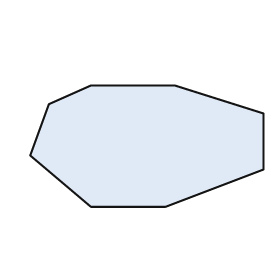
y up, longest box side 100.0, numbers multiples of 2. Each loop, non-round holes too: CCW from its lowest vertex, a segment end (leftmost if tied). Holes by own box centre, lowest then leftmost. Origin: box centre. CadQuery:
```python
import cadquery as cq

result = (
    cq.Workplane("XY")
    .moveTo(-24.0, -26.0)
    .lineTo(8.0, -26.0)
    .lineTo(50.0, -10.0)
    .lineTo(50.0, 14.0)
    .lineTo(12.0, 26.0)
    .lineTo(-24.0, 26.0)
    .lineTo(-42.0, 18.0)
    .lineTo(-50.0, -4.0)
    .close()
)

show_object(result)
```